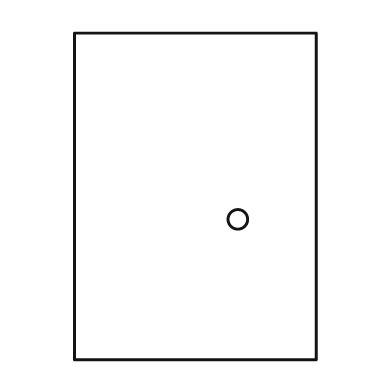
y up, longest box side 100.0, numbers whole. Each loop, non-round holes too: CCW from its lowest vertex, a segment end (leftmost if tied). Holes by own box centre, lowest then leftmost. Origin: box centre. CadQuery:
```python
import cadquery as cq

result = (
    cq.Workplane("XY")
    .moveTo(-37.0, -50.0)
    .lineTo(37.0, -50.0)
    .lineTo(37.0, 50.0)
    .lineTo(-37.0, 50.0)
    .close()
    .moveTo(13.0, -7.0)
    .circle(3.0)
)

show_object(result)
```